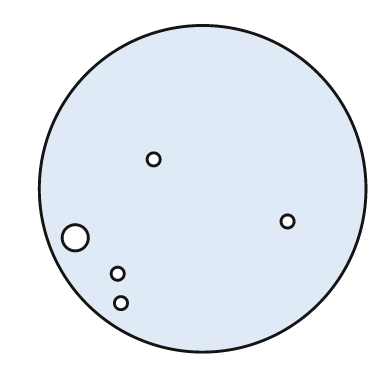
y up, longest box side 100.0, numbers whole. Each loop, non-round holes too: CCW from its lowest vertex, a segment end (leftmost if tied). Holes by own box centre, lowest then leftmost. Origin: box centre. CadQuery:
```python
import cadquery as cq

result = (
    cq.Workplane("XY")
    .moveTo(0.0, 0.0)
    .circle(50.0)
    .moveTo(-25.0, -35.0)
    .circle(2.0)
    .moveTo(-26.0, -26.0)
    .circle(2.0)
    .moveTo(-39.0, -15.0)
    .circle(4.0)
    .moveTo(26.0, -10.0)
    .circle(2.0)
    .moveTo(-15.0, 9.0)
    .circle(2.0)
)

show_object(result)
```